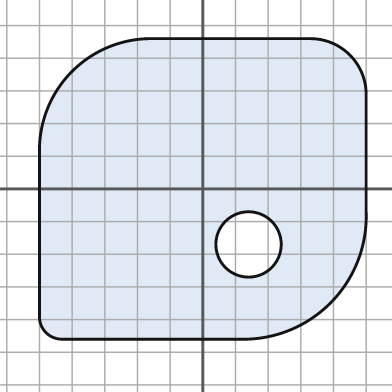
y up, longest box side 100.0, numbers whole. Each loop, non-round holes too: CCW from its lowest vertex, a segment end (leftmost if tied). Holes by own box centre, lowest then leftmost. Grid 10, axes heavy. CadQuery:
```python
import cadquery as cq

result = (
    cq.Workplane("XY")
    .moveTo(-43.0, -46.0)
    .lineTo(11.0, -46.0)
    .threePointArc((39.0, -35.0), (50.0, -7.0))
    .lineTo(50.0, 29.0)
    .threePointArc((45.0, 41.0), (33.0, 46.0))
    .lineTo(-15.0, 46.0)
    .threePointArc((-40.0, 36.0), (-50.0, 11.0))
    .lineTo(-50.0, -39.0)
    .threePointArc((-48.0, -44.0), (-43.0, -46.0))
    .close()
    .moveTo(14.0, -17.0)
    .circle(10.0)
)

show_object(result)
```